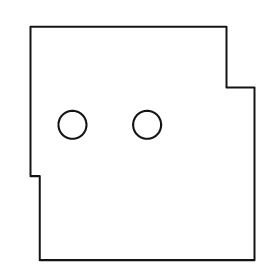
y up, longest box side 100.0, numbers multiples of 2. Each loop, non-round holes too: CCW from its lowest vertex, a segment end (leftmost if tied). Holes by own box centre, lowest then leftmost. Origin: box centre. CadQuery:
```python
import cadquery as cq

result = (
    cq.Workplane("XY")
    .moveTo(-44.0, -50.0)
    .lineTo(48.0, -50.0)
    .lineTo(48.0, 24.0)
    .lineTo(36.0, 24.0)
    .lineTo(36.0, 50.0)
    .lineTo(-48.0, 50.0)
    .lineTo(-48.0, -14.0)
    .lineTo(-44.0, -14.0)
    .close()
    .moveTo(-30.0, 8.0)
    .circle(6.0)
    .moveTo(2.0, 8.0)
    .circle(6.0)
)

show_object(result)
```